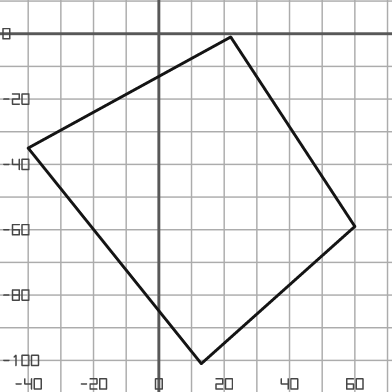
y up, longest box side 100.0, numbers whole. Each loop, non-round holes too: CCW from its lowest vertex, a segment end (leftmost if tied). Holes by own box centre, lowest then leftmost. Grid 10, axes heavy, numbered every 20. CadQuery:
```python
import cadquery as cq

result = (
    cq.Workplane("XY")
    .moveTo(13.0, -101.0)
    .lineTo(60.0, -59.0)
    .lineTo(22.0, -1.0)
    .lineTo(-40.0, -35.0)
    .close()
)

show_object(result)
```